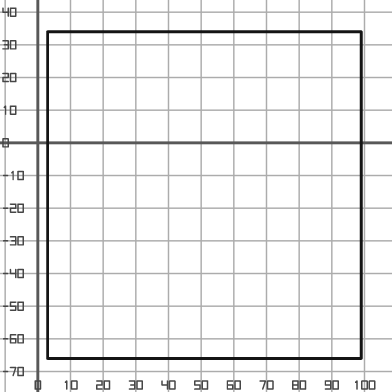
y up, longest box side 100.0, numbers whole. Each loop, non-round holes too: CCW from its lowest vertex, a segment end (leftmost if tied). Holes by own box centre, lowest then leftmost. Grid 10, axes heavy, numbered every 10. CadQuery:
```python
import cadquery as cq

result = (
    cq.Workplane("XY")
    .moveTo(3.0, -66.0)
    .lineTo(99.0, -66.0)
    .lineTo(99.0, 34.0)
    .lineTo(3.0, 34.0)
    .close()
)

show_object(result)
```